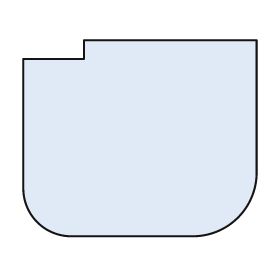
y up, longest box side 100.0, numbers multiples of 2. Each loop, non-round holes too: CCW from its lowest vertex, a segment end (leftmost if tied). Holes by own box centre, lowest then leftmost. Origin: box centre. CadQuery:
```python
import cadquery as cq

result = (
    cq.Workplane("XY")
    .moveTo(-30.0, -42.0)
    .lineTo(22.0, -42.0)
    .threePointArc((42.0, -34.0), (50.0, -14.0))
    .lineTo(50.0, 42.0)
    .lineTo(-24.0, 42.0)
    .lineTo(-24.0, 34.0)
    .lineTo(-50.0, 34.0)
    .lineTo(-50.0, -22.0)
    .threePointArc((-44.0, -36.0), (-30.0, -42.0))
    .close()
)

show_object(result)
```